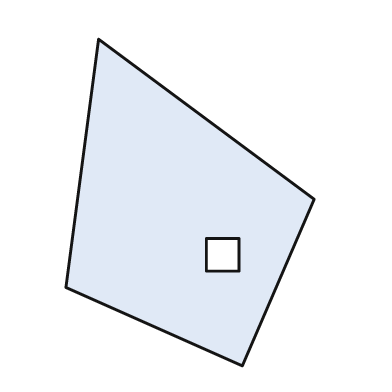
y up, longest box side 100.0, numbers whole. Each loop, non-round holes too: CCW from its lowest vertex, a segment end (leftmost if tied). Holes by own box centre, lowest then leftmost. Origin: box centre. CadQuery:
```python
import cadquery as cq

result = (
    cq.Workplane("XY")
    .moveTo(16.0, -50.0)
    .lineTo(38.0, 1.0)
    .lineTo(-28.0, 50.0)
    .lineTo(-38.0, -26.0)
    .close()
    .moveTo(5.0, -21.0)
    .lineTo(15.0, -21.0)
    .lineTo(15.0, -11.0)
    .lineTo(5.0, -11.0)
    .close()
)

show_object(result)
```